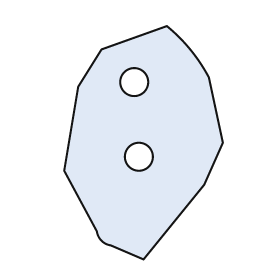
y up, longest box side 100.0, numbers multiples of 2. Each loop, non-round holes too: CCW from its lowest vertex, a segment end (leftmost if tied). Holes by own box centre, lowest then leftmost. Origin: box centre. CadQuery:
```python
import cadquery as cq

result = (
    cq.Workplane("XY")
    .moveTo(0.0, -50.0)
    .lineTo(26.0, -18.0)
    .lineTo(34.0, 0.0)
    .lineTo(28.0, 28.0)
    .threePointArc((20.0, 40.0), (10.0, 50.0))
    .lineTo(-18.0, 40.0)
    .lineTo(-28.0, 24.0)
    .lineTo(-34.0, -12.0)
    .lineTo(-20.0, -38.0)
    .threePointArc((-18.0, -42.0), (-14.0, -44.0))
    .close()
    .moveTo(-2.0, -6.0)
    .circle(6.0)
    .moveTo(-4.0, 26.0)
    .circle(6.0)
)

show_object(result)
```